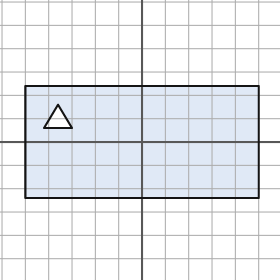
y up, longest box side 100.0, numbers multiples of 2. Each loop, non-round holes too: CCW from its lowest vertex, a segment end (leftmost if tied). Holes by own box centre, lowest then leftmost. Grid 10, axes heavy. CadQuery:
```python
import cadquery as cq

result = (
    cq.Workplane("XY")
    .moveTo(-50.0, -24.0)
    .lineTo(50.0, -24.0)
    .lineTo(50.0, 24.0)
    .lineTo(-50.0, 24.0)
    .close()
    .moveTo(-42.0, 6.0)
    .lineTo(-30.0, 6.0)
    .lineTo(-36.0, 16.0)
    .close()
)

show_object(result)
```